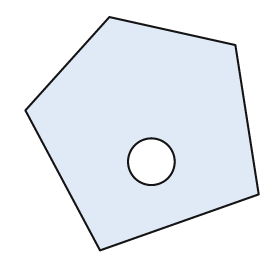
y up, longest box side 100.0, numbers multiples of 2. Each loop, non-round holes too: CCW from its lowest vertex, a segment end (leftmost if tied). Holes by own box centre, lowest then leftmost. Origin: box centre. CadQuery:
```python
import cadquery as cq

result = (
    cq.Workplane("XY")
    .moveTo(-18.0, -50.0)
    .lineTo(50.0, -26.0)
    .lineTo(40.0, 38.0)
    .lineTo(-14.0, 50.0)
    .lineTo(-50.0, 10.0)
    .close()
    .moveTo(4.0, -12.0)
    .circle(10.0)
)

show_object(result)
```